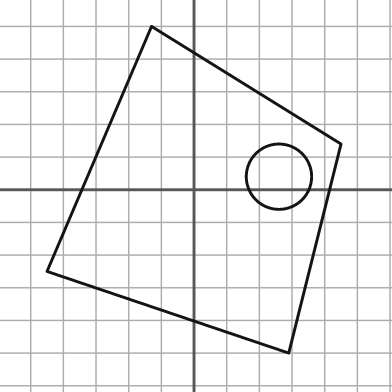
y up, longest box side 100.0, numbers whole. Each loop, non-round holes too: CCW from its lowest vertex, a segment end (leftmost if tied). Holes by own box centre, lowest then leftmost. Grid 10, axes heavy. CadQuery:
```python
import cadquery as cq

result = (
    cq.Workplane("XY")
    .moveTo(29.0, -50.0)
    .lineTo(45.0, 14.0)
    .lineTo(-13.0, 50.0)
    .lineTo(-45.0, -25.0)
    .close()
    .moveTo(26.0, 4.0)
    .circle(10.0)
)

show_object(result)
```